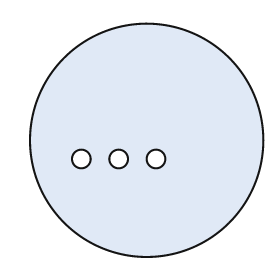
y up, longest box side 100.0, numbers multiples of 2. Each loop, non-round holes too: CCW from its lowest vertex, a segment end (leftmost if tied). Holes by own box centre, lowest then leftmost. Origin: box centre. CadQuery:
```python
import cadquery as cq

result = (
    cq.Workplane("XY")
    .moveTo(0.0, 0.0)
    .circle(50.0)
    .moveTo(-28.0, -8.0)
    .circle(4.0)
    .moveTo(-12.0, -8.0)
    .circle(4.0)
    .moveTo(4.0, -8.0)
    .circle(4.0)
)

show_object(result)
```